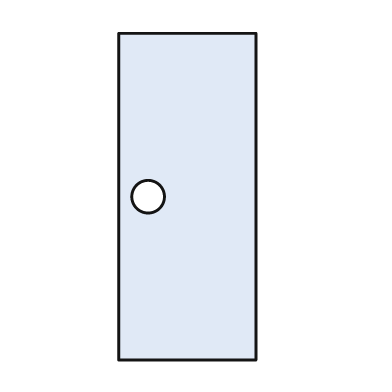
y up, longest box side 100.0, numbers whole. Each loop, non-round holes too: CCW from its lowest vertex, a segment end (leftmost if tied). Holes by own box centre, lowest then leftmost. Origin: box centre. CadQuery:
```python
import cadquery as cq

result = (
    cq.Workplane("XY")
    .moveTo(-21.0, -50.0)
    .lineTo(21.0, -50.0)
    .lineTo(21.0, 50.0)
    .lineTo(-21.0, 50.0)
    .close()
    .moveTo(-12.0, 0.0)
    .circle(5.0)
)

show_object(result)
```